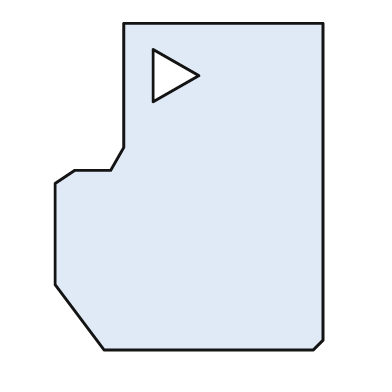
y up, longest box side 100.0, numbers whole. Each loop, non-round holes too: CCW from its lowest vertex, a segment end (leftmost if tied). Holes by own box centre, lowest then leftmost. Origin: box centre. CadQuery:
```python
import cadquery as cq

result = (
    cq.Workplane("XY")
    .moveTo(-26.0, -50.0)
    .lineTo(38.0, -50.0)
    .lineTo(41.0, -47.0)
    .lineTo(41.0, 50.0)
    .lineTo(-20.0, 50.0)
    .lineTo(-20.0, 12.0)
    .lineTo(-24.0, 5.0)
    .lineTo(-35.0, 5.0)
    .lineTo(-41.0, 1.0)
    .lineTo(-41.0, -30.0)
    .close()
    .moveTo(-11.0, 26.0)
    .lineTo(3.0, 34.0)
    .lineTo(-11.0, 42.0)
    .close()
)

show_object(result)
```